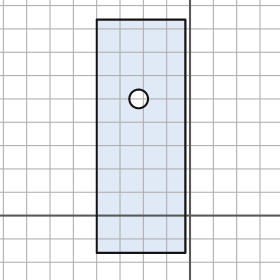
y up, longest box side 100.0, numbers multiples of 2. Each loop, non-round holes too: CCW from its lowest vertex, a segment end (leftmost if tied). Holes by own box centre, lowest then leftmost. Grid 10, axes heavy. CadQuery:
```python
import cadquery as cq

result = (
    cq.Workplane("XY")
    .moveTo(-40.0, -16.0)
    .lineTo(-2.0, -16.0)
    .lineTo(-2.0, 84.0)
    .lineTo(-40.0, 84.0)
    .close()
    .moveTo(-22.0, 50.0)
    .circle(4.0)
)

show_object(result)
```